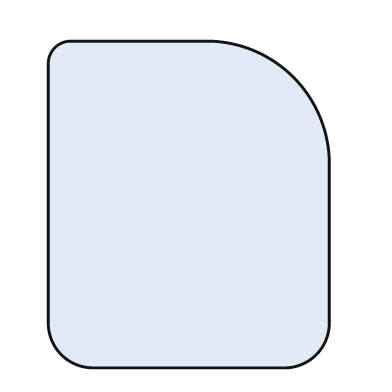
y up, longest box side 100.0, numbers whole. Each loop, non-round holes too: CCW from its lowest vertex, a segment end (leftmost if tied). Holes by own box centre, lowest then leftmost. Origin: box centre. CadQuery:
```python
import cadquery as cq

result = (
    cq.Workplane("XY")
    .moveTo(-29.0, -50.0)
    .lineTo(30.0, -50.0)
    .threePointArc((39.0, -46.0), (43.0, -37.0))
    .lineTo(43.0, 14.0)
    .threePointArc((32.0, 39.0), (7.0, 50.0))
    .lineTo(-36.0, 50.0)
    .threePointArc((-41.0, 48.0), (-43.0, 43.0))
    .lineTo(-43.0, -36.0)
    .threePointArc((-39.0, -46.0), (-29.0, -50.0))
    .close()
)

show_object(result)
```